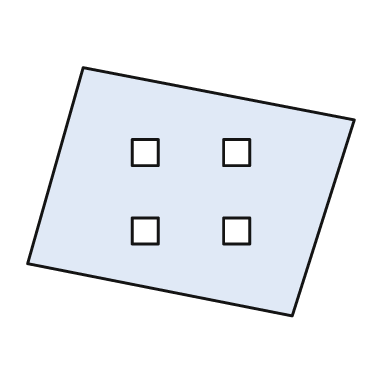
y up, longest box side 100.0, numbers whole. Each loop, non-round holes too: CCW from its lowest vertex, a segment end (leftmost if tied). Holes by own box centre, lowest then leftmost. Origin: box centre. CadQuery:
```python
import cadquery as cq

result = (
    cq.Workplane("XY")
    .moveTo(31.0, -38.0)
    .lineTo(50.0, 22.0)
    .lineTo(-33.0, 38.0)
    .lineTo(-50.0, -22.0)
    .close()
    .moveTo(-18.0, -16.0)
    .lineTo(-10.0, -16.0)
    .lineTo(-10.0, -8.0)
    .lineTo(-18.0, -8.0)
    .close()
    .moveTo(10.0, -16.0)
    .lineTo(18.0, -16.0)
    .lineTo(18.0, -8.0)
    .lineTo(10.0, -8.0)
    .close()
    .moveTo(-18.0, 8.0)
    .lineTo(-10.0, 8.0)
    .lineTo(-10.0, 16.0)
    .lineTo(-18.0, 16.0)
    .close()
    .moveTo(10.0, 8.0)
    .lineTo(18.0, 8.0)
    .lineTo(18.0, 16.0)
    .lineTo(10.0, 16.0)
    .close()
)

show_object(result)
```